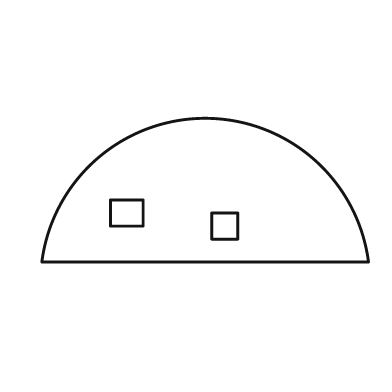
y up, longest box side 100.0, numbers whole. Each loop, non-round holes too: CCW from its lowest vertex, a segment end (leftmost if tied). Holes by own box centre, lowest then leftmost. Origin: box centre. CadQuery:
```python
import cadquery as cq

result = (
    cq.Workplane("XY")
    .moveTo(-50.0, -22.0)
    .lineTo(50.0, -22.0)
    .threePointArc((0.0, 22.0), (-50.0, -22.0))
    .close()
    .moveTo(2.0, -15.0)
    .lineTo(10.0, -15.0)
    .lineTo(10.0, -7.0)
    .lineTo(2.0, -7.0)
    .close()
    .moveTo(-29.0, -11.0)
    .lineTo(-19.0, -11.0)
    .lineTo(-19.0, -3.0)
    .lineTo(-29.0, -3.0)
    .close()
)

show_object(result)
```